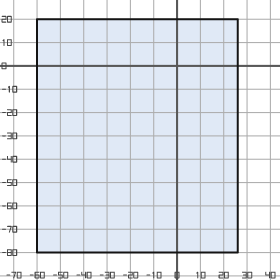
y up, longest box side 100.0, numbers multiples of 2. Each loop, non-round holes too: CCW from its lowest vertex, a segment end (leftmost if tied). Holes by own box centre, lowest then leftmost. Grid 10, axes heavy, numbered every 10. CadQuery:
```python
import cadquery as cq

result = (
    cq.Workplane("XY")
    .moveTo(-60.0, -80.0)
    .lineTo(26.0, -80.0)
    .lineTo(26.0, 20.0)
    .lineTo(-60.0, 20.0)
    .close()
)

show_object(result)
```